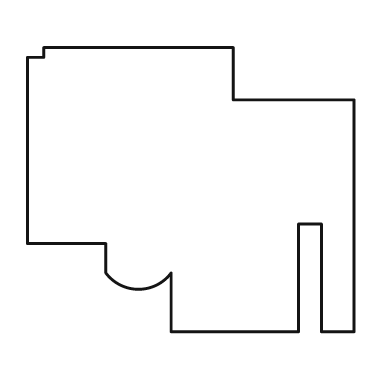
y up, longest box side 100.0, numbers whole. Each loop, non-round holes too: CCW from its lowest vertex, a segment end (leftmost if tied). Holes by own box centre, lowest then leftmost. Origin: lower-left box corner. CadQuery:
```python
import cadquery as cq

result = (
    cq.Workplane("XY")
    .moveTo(44.0, 0.0)
    .lineTo(83.0, 0.0)
    .lineTo(83.0, 33.0)
    .lineTo(90.0, 33.0)
    .lineTo(90.0, 0.0)
    .lineTo(100.0, 0.0)
    .lineTo(100.0, 71.0)
    .lineTo(63.0, 71.0)
    .lineTo(63.0, 87.0)
    .lineTo(5.0, 87.0)
    .lineTo(5.0, 84.0)
    .lineTo(0.0, 84.0)
    .lineTo(0.0, 27.0)
    .lineTo(24.0, 27.0)
    .lineTo(24.0, 18.0)
    .threePointArc((34.0, 13.0), (44.0, 18.0))
    .close()
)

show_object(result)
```